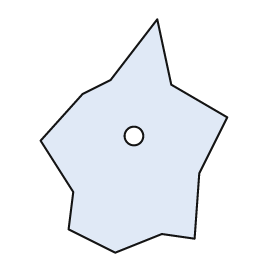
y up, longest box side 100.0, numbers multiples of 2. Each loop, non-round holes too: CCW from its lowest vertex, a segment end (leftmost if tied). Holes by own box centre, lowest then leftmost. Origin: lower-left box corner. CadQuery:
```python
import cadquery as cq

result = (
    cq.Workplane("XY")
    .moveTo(32.0, 0.0)
    .lineTo(52.0, 8.0)
    .lineTo(66.0, 6.0)
    .lineTo(68.0, 34.0)
    .lineTo(80.0, 58.0)
    .lineTo(56.0, 72.0)
    .lineTo(50.0, 100.0)
    .lineTo(30.0, 74.0)
    .lineTo(18.0, 68.0)
    .lineTo(0.0, 48.0)
    .lineTo(14.0, 26.0)
    .lineTo(12.0, 10.0)
    .close()
    .moveTo(40.0, 50.0)
    .circle(4.0)
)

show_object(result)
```